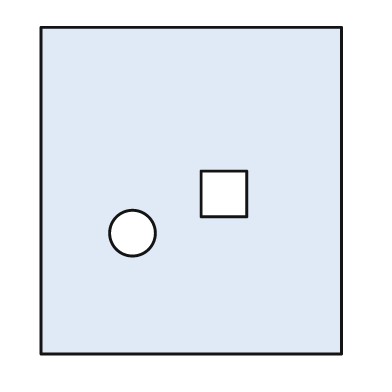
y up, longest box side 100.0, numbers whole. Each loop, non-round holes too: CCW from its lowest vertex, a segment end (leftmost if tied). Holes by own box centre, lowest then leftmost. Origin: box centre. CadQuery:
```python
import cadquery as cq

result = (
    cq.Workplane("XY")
    .moveTo(-46.0, -50.0)
    .lineTo(46.0, -50.0)
    .lineTo(46.0, 50.0)
    .lineTo(-46.0, 50.0)
    .close()
    .moveTo(-18.0, -13.0)
    .circle(7.0)
    .moveTo(3.0, -8.0)
    .lineTo(17.0, -8.0)
    .lineTo(17.0, 6.0)
    .lineTo(3.0, 6.0)
    .close()
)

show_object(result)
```